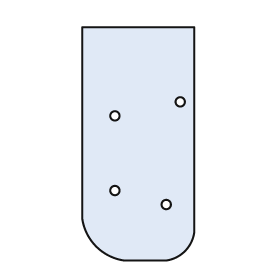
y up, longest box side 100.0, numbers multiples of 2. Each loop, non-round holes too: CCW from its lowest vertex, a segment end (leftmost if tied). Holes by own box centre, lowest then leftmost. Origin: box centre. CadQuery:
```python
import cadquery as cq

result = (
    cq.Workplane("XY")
    .moveTo(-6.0, -50.0)
    .lineTo(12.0, -50.0)
    .threePointArc((20.0, -46.0), (24.0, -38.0))
    .lineTo(24.0, 50.0)
    .lineTo(-24.0, 50.0)
    .lineTo(-24.0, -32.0)
    .threePointArc((-18.0, -44.0), (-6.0, -50.0))
    .close()
    .moveTo(12.0, -26.0)
    .circle(2.0)
    .moveTo(-10.0, -20.0)
    .circle(2.0)
    .moveTo(-10.0, 12.0)
    .circle(2.0)
    .moveTo(18.0, 18.0)
    .circle(2.0)
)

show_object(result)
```